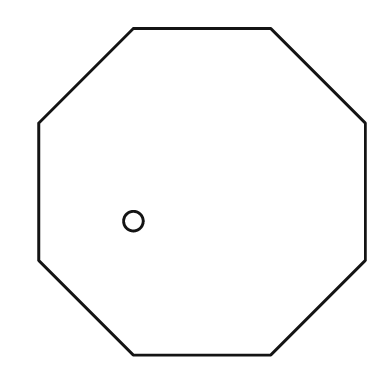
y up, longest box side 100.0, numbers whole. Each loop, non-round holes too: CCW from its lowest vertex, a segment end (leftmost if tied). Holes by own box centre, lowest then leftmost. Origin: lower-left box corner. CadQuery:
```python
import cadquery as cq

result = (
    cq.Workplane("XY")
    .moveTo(29.0, 0.0)
    .lineTo(71.0, 0.0)
    .lineTo(100.0, 29.0)
    .lineTo(100.0, 71.0)
    .lineTo(71.0, 100.0)
    .lineTo(29.0, 100.0)
    .lineTo(0.0, 71.0)
    .lineTo(0.0, 29.0)
    .close()
    .moveTo(29.0, 41.0)
    .circle(3.0)
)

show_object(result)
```